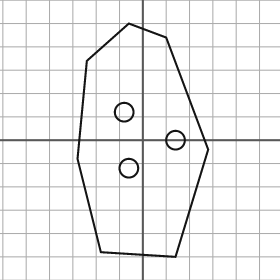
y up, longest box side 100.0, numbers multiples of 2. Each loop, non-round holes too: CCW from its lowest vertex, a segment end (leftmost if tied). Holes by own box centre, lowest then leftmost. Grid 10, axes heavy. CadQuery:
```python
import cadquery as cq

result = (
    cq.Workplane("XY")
    .moveTo(14.0, -50.0)
    .lineTo(28.0, -4.0)
    .lineTo(10.0, 44.0)
    .lineTo(-6.0, 50.0)
    .lineTo(-24.0, 34.0)
    .lineTo(-28.0, -8.0)
    .lineTo(-18.0, -48.0)
    .close()
    .moveTo(-6.0, -12.0)
    .circle(4.0)
    .moveTo(14.0, 0.0)
    .circle(4.0)
    .moveTo(-8.0, 12.0)
    .circle(4.0)
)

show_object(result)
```